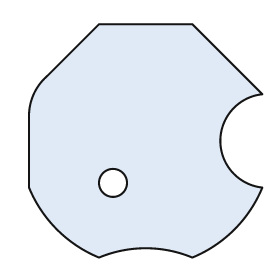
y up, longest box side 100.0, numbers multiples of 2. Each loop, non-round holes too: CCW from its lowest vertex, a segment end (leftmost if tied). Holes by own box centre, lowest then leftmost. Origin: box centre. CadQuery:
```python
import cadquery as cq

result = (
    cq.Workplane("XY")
    .moveTo(-20.0, -50.0)
    .threePointArc((0.0, -46.0), (20.0, -50.0))
    .threePointArc((38.0, -38.0), (50.0, -20.0))
    .threePointArc((32.0, 0.0), (50.0, 20.0))
    .lineTo(20.0, 50.0)
    .lineTo(-20.0, 50.0)
    .lineTo(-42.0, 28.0)
    .threePointArc((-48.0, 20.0), (-50.0, 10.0))
    .lineTo(-50.0, -20.0)
    .threePointArc((-38.0, -38.0), (-20.0, -50.0))
    .close()
    .moveTo(-14.0, -18.0)
    .circle(6.0)
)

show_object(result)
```